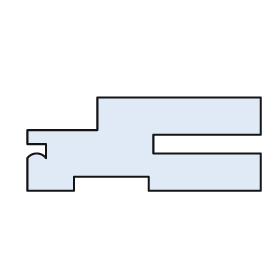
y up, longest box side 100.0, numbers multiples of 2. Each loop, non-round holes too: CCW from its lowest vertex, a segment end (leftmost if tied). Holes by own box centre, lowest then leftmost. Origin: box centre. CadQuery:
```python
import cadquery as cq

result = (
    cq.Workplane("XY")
    .moveTo(-50.0, -20.0)
    .lineTo(-30.0, -20.0)
    .lineTo(-30.0, -14.0)
    .lineTo(2.0, -14.0)
    .lineTo(2.0, -20.0)
    .lineTo(50.0, -20.0)
    .lineTo(50.0, -4.0)
    .lineTo(4.0, -4.0)
    .lineTo(4.0, 4.0)
    .lineTo(50.0, 4.0)
    .lineTo(50.0, 20.0)
    .lineTo(-20.0, 20.0)
    .lineTo(-20.0, 6.0)
    .lineTo(-50.0, 6.0)
    .lineTo(-50.0, 0.0)
    .lineTo(-42.0, 0.0)
    .lineTo(-42.0, -6.0)
    .threePointArc((-46.0, -4.0), (-50.0, -6.0))
    .close()
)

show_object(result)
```